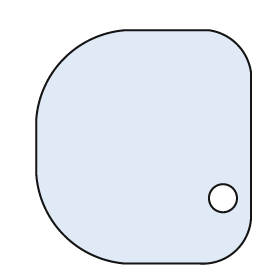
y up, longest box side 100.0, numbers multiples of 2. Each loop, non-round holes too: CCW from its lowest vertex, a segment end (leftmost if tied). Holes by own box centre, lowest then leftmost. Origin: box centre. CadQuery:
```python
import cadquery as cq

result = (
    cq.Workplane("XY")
    .moveTo(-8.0, -50.0)
    .lineTo(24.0, -50.0)
    .threePointArc((40.0, -44.0), (46.0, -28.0))
    .lineTo(46.0, 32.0)
    .threePointArc((40.0, 44.0), (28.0, 50.0))
    .lineTo(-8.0, 50.0)
    .threePointArc((-34.0, 38.0), (-46.0, 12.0))
    .lineTo(-46.0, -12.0)
    .threePointArc((-34.0, -38.0), (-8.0, -50.0))
    .close()
    .moveTo(34.0, -22.0)
    .circle(6.0)
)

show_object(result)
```